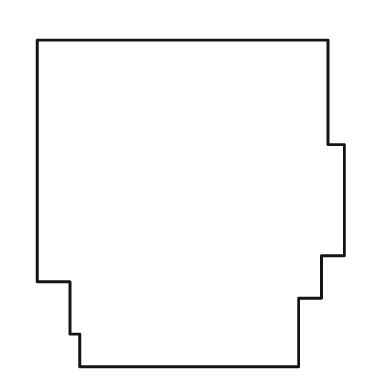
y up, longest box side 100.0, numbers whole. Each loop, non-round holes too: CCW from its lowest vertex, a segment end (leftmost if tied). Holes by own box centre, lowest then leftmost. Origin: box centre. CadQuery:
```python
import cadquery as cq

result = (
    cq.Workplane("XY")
    .moveTo(-34.0, -50.0)
    .lineTo(33.0, -50.0)
    .lineTo(33.0, -29.0)
    .lineTo(40.0, -29.0)
    .lineTo(40.0, -16.0)
    .lineTo(47.0, -16.0)
    .lineTo(47.0, 18.0)
    .lineTo(42.0, 18.0)
    .lineTo(42.0, 50.0)
    .lineTo(-47.0, 50.0)
    .lineTo(-47.0, -24.0)
    .lineTo(-37.0, -24.0)
    .lineTo(-37.0, -40.0)
    .lineTo(-34.0, -40.0)
    .close()
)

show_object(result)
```